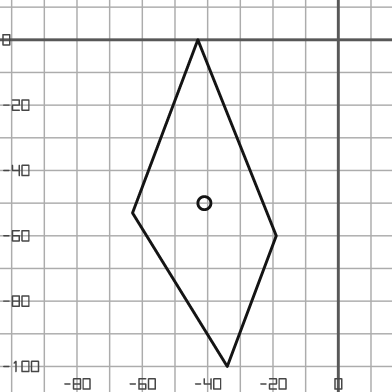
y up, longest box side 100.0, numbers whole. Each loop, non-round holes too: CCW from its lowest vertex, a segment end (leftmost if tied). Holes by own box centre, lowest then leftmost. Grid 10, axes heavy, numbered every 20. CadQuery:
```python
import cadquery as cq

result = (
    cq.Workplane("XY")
    .moveTo(-34.0, -100.0)
    .lineTo(-19.0, -60.0)
    .lineTo(-43.0, 0.0)
    .lineTo(-63.0, -53.0)
    .close()
    .moveTo(-41.0, -50.0)
    .circle(2.0)
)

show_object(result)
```